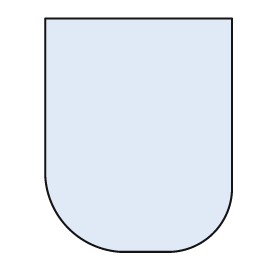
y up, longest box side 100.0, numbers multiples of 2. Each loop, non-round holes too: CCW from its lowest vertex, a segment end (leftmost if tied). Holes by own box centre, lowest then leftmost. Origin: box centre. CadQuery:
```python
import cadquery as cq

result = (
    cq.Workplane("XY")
    .moveTo(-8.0, -50.0)
    .lineTo(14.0, -50.0)
    .threePointArc((32.0, -42.0), (40.0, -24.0))
    .lineTo(40.0, 50.0)
    .lineTo(-40.0, 50.0)
    .lineTo(-40.0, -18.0)
    .threePointArc((-30.0, -40.0), (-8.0, -50.0))
    .close()
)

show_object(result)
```